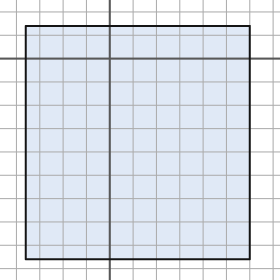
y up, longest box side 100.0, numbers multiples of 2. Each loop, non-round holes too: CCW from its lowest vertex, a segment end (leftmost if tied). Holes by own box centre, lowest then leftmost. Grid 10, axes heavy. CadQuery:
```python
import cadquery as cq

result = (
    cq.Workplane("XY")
    .moveTo(-36.0, -86.0)
    .lineTo(60.0, -86.0)
    .lineTo(60.0, 14.0)
    .lineTo(-36.0, 14.0)
    .close()
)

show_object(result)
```